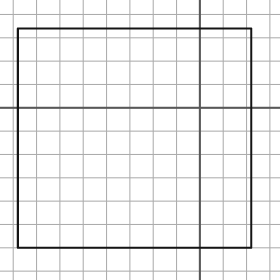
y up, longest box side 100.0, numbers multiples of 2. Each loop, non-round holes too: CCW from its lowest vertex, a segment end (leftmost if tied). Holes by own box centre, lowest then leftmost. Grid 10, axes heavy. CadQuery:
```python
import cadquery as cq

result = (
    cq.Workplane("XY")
    .moveTo(-78.0, -60.0)
    .lineTo(22.0, -60.0)
    .lineTo(22.0, 34.0)
    .lineTo(-78.0, 34.0)
    .close()
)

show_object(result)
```